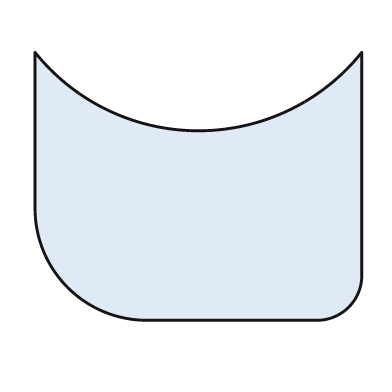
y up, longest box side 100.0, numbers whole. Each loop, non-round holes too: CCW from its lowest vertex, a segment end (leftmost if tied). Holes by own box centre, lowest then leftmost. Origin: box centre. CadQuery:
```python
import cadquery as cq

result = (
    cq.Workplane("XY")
    .moveTo(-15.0, -41.0)
    .lineTo(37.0, -41.0)
    .threePointArc((46.0, -37.0), (50.0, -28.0))
    .lineTo(50.0, 41.0)
    .threePointArc((0.0, 17.0), (-50.0, 41.0))
    .lineTo(-50.0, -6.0)
    .threePointArc((-40.0, -31.0), (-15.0, -41.0))
    .close()
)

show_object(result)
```